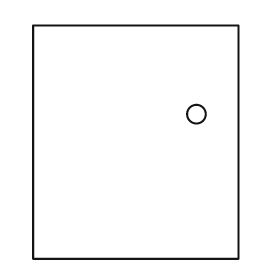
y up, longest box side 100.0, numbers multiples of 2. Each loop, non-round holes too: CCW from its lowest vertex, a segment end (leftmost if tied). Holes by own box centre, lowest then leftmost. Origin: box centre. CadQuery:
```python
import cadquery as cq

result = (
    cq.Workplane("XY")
    .moveTo(-44.0, -50.0)
    .lineTo(44.0, -50.0)
    .lineTo(44.0, 50.0)
    .lineTo(-44.0, 50.0)
    .close()
    .moveTo(26.0, 12.0)
    .circle(4.0)
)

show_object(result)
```